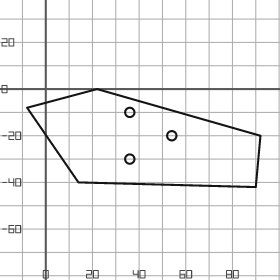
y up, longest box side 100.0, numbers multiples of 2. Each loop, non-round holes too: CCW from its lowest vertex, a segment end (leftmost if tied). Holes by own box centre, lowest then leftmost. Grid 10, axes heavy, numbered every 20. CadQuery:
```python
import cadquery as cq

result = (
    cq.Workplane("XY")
    .moveTo(90.0, -42.0)
    .lineTo(92.0, -20.0)
    .lineTo(22.0, 0.0)
    .lineTo(-8.0, -8.0)
    .lineTo(14.0, -40.0)
    .close()
    .moveTo(36.0, -30.0)
    .circle(2.0)
    .moveTo(54.0, -20.0)
    .circle(2.0)
    .moveTo(36.0, -10.0)
    .circle(2.0)
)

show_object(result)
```